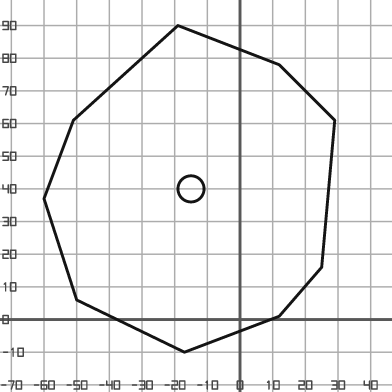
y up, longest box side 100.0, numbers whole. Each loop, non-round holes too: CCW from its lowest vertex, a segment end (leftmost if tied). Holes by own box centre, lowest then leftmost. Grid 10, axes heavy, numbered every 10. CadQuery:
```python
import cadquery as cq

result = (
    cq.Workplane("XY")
    .moveTo(-17.0, -10.0)
    .lineTo(12.0, 1.0)
    .lineTo(25.0, 16.0)
    .lineTo(29.0, 61.0)
    .lineTo(12.0, 78.0)
    .lineTo(-19.0, 90.0)
    .lineTo(-51.0, 61.0)
    .lineTo(-60.0, 37.0)
    .lineTo(-50.0, 6.0)
    .close()
    .moveTo(-15.0, 40.0)
    .circle(4.0)
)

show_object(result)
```